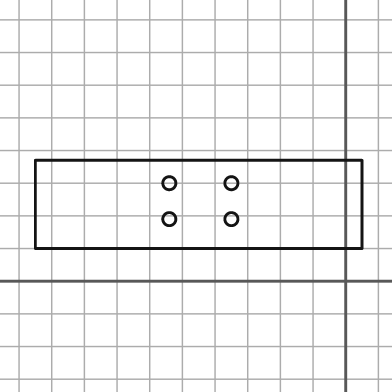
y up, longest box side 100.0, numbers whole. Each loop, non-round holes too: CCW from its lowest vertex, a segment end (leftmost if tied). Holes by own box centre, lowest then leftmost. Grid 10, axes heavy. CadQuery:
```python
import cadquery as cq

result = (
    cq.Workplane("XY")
    .moveTo(-95.0, 10.0)
    .lineTo(5.0, 10.0)
    .lineTo(5.0, 37.0)
    .lineTo(-95.0, 37.0)
    .close()
    .moveTo(-54.0, 19.0)
    .circle(2.0)
    .moveTo(-35.0, 19.0)
    .circle(2.0)
    .moveTo(-54.0, 30.0)
    .circle(2.0)
    .moveTo(-35.0, 30.0)
    .circle(2.0)
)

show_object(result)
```